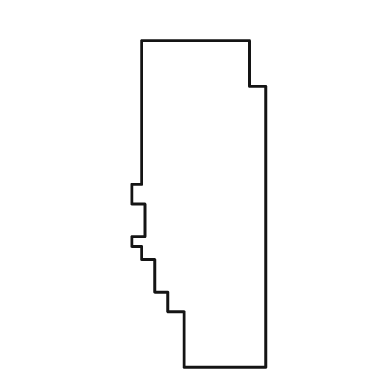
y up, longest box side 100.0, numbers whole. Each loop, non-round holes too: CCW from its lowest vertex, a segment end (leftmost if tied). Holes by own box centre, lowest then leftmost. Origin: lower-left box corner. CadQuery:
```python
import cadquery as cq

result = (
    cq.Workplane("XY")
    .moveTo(16.0, 0.0)
    .lineTo(41.0, 0.0)
    .lineTo(41.0, 86.0)
    .lineTo(36.0, 86.0)
    .lineTo(36.0, 100.0)
    .lineTo(3.0, 100.0)
    .lineTo(3.0, 56.0)
    .lineTo(0.0, 56.0)
    .lineTo(0.0, 50.0)
    .lineTo(4.0, 50.0)
    .lineTo(4.0, 40.0)
    .lineTo(0.0, 40.0)
    .lineTo(0.0, 37.0)
    .lineTo(3.0, 37.0)
    .lineTo(3.0, 33.0)
    .lineTo(7.0, 33.0)
    .lineTo(7.0, 23.0)
    .lineTo(11.0, 23.0)
    .lineTo(11.0, 17.0)
    .lineTo(16.0, 17.0)
    .close()
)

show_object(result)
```